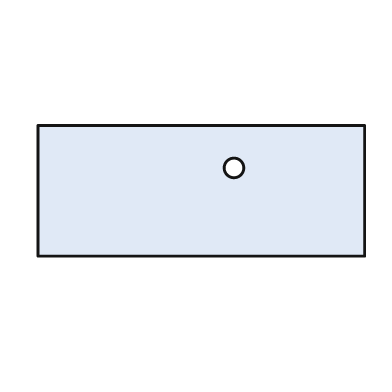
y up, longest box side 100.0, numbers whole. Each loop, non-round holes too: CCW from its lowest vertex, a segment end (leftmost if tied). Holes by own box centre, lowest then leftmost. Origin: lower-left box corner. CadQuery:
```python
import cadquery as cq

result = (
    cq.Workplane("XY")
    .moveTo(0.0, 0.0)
    .lineTo(100.0, 0.0)
    .lineTo(100.0, 40.0)
    .lineTo(0.0, 40.0)
    .close()
    .moveTo(60.0, 27.0)
    .circle(3.0)
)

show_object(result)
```